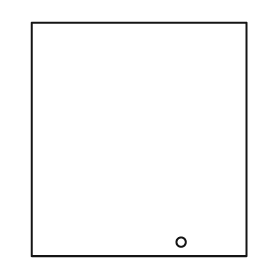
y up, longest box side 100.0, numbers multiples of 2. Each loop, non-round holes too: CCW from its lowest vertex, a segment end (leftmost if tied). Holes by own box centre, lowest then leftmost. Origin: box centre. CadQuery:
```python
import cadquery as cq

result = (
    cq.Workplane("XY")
    .moveTo(-46.0, -50.0)
    .lineTo(46.0, -50.0)
    .lineTo(46.0, 50.0)
    .lineTo(-46.0, 50.0)
    .close()
    .moveTo(18.0, -44.0)
    .circle(2.0)
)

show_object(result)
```